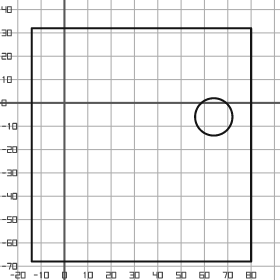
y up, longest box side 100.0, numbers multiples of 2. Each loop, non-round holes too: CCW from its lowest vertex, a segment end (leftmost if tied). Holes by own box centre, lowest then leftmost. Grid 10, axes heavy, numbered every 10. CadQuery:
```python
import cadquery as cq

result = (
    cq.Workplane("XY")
    .moveTo(-14.0, -68.0)
    .lineTo(80.0, -68.0)
    .lineTo(80.0, 32.0)
    .lineTo(-14.0, 32.0)
    .close()
    .moveTo(64.0, -6.0)
    .circle(8.0)
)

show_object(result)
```